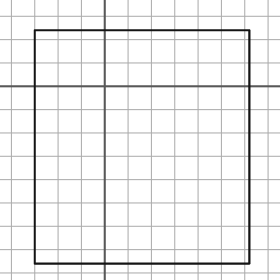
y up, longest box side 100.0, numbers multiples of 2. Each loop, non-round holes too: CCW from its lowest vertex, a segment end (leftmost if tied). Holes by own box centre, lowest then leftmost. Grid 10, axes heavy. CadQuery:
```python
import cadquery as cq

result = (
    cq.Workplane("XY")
    .moveTo(-30.0, -76.0)
    .lineTo(62.0, -76.0)
    .lineTo(62.0, 24.0)
    .lineTo(-30.0, 24.0)
    .close()
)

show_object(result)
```